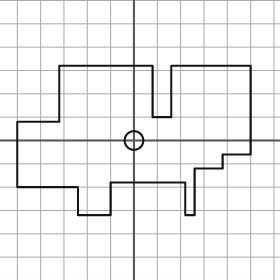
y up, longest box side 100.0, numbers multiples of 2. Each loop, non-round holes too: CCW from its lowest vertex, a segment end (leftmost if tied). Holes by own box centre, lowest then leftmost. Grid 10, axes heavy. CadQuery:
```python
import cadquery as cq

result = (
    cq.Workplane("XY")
    .moveTo(-24.0, -32.0)
    .lineTo(-10.0, -32.0)
    .lineTo(-10.0, -18.0)
    .lineTo(22.0, -18.0)
    .lineTo(22.0, -32.0)
    .lineTo(26.0, -32.0)
    .lineTo(26.0, -12.0)
    .lineTo(38.0, -12.0)
    .lineTo(38.0, -6.0)
    .lineTo(50.0, -6.0)
    .lineTo(50.0, 32.0)
    .lineTo(16.0, 32.0)
    .lineTo(16.0, 10.0)
    .lineTo(8.0, 10.0)
    .lineTo(8.0, 32.0)
    .lineTo(-32.0, 32.0)
    .lineTo(-32.0, 8.0)
    .lineTo(-50.0, 8.0)
    .lineTo(-50.0, -20.0)
    .lineTo(-24.0, -20.0)
    .close()
    .moveTo(0.0, 0.0)
    .circle(4.0)
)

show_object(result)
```